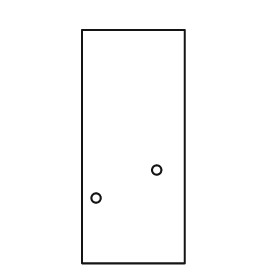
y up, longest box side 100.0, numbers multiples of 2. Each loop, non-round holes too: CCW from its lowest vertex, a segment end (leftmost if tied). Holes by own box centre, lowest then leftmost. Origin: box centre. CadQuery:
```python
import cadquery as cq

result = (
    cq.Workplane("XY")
    .moveTo(-22.0, -50.0)
    .lineTo(22.0, -50.0)
    .lineTo(22.0, 50.0)
    .lineTo(-22.0, 50.0)
    .close()
    .moveTo(-16.0, -22.0)
    .circle(2.0)
    .moveTo(10.0, -10.0)
    .circle(2.0)
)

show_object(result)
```